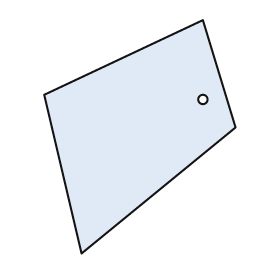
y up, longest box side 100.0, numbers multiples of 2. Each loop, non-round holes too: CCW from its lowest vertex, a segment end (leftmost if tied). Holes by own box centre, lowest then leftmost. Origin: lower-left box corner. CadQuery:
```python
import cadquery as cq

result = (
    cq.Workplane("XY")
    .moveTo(16.0, 0.0)
    .lineTo(82.0, 54.0)
    .lineTo(68.0, 100.0)
    .lineTo(0.0, 68.0)
    .close()
    .moveTo(68.0, 66.0)
    .circle(2.0)
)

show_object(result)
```